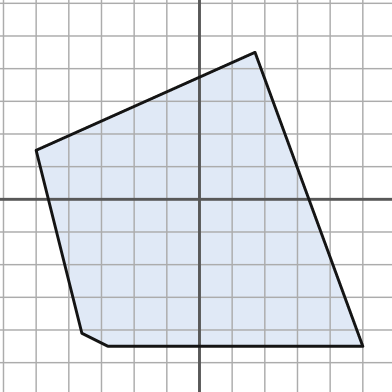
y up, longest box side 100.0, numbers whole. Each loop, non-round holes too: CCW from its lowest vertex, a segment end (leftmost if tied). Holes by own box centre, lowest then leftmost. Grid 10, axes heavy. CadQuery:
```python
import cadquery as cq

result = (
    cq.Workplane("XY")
    .moveTo(-28.0, -45.0)
    .lineTo(50.0, -45.0)
    .lineTo(17.0, 45.0)
    .lineTo(-50.0, 15.0)
    .lineTo(-36.0, -41.0)
    .close()
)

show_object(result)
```